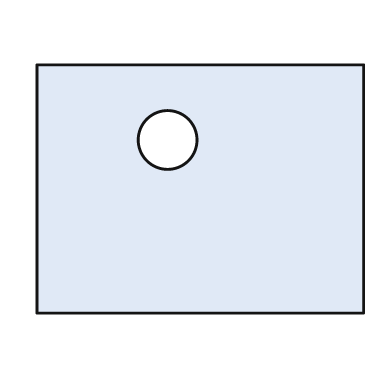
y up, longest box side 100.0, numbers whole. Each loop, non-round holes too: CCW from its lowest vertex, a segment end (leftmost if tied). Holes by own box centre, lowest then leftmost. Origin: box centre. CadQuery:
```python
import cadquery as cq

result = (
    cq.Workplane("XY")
    .moveTo(-50.0, -38.0)
    .lineTo(50.0, -38.0)
    .lineTo(50.0, 38.0)
    .lineTo(-50.0, 38.0)
    .close()
    .moveTo(-10.0, 15.0)
    .circle(9.0)
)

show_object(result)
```